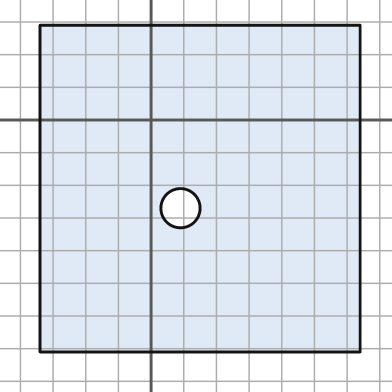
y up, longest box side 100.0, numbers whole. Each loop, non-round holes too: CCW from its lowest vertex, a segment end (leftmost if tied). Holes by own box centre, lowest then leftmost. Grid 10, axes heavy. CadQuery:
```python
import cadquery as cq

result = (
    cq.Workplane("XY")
    .moveTo(-34.0, -71.0)
    .lineTo(64.0, -71.0)
    .lineTo(64.0, 29.0)
    .lineTo(-34.0, 29.0)
    .close()
    .moveTo(9.0, -27.0)
    .circle(6.0)
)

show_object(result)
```